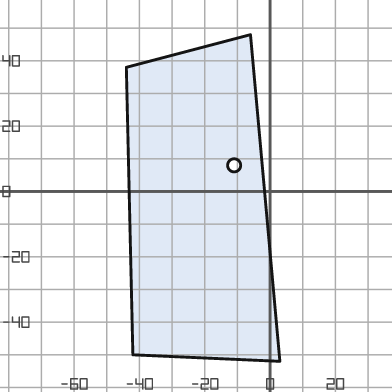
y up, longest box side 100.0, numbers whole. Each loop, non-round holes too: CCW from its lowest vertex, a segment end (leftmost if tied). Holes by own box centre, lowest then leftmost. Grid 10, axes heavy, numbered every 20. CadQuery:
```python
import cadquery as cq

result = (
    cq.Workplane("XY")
    .moveTo(3.0, -52.0)
    .lineTo(-6.0, 48.0)
    .lineTo(-44.0, 38.0)
    .lineTo(-42.0, -50.0)
    .close()
    .moveTo(-11.0, 8.0)
    .circle(2.0)
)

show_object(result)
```